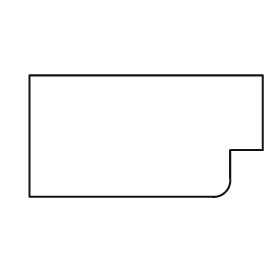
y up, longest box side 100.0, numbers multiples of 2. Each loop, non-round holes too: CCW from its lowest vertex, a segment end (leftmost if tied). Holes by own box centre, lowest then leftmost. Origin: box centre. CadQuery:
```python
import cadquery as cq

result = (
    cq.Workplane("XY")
    .moveTo(-50.0, -26.0)
    .lineTo(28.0, -26.0)
    .threePointArc((34.0, -24.0), (36.0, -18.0))
    .lineTo(36.0, -6.0)
    .lineTo(50.0, -6.0)
    .lineTo(50.0, 26.0)
    .lineTo(-50.0, 26.0)
    .close()
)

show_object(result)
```